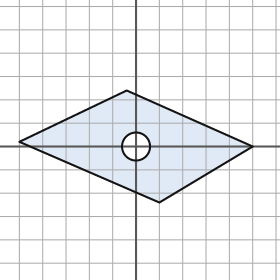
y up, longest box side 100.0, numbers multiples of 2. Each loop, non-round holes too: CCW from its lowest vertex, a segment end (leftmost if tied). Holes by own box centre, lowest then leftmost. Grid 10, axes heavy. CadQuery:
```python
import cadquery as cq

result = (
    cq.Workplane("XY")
    .moveTo(10.0, -24.0)
    .lineTo(50.0, 0.0)
    .lineTo(-4.0, 24.0)
    .lineTo(-50.0, 2.0)
    .close()
    .moveTo(0.0, 0.0)
    .circle(6.0)
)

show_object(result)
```